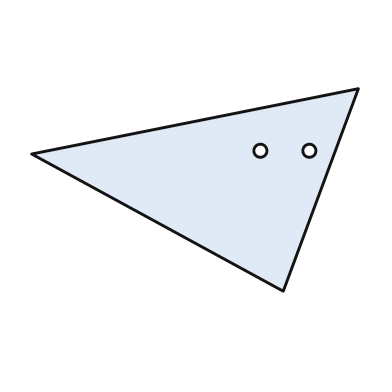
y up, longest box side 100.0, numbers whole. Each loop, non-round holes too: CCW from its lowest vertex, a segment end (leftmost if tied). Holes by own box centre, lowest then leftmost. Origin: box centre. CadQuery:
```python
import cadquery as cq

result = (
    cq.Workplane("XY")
    .moveTo(27.0, -31.0)
    .lineTo(50.0, 31.0)
    .lineTo(-50.0, 11.0)
    .close()
    .moveTo(20.0, 12.0)
    .circle(2.0)
    .moveTo(35.0, 12.0)
    .circle(2.0)
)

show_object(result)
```